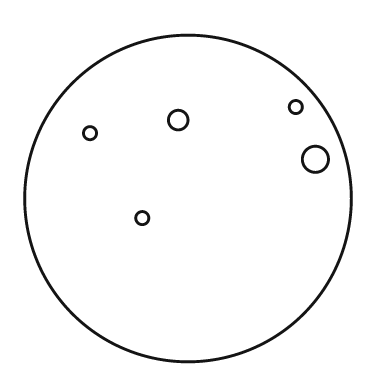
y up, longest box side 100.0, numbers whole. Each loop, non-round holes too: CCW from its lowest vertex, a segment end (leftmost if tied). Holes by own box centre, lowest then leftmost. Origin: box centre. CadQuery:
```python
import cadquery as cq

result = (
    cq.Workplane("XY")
    .moveTo(0.0, 0.0)
    .circle(50.0)
    .moveTo(-14.0, -6.0)
    .circle(2.0)
    .moveTo(39.0, 12.0)
    .circle(4.0)
    .moveTo(-30.0, 20.0)
    .circle(2.0)
    .moveTo(-3.0, 24.0)
    .circle(3.0)
    .moveTo(33.0, 28.0)
    .circle(2.0)
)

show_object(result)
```